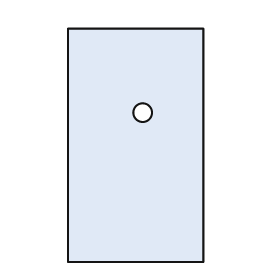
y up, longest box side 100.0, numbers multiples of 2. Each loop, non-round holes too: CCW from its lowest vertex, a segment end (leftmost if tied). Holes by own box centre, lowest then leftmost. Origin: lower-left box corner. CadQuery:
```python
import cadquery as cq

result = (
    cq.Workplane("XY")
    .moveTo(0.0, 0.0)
    .lineTo(58.0, 0.0)
    .lineTo(58.0, 100.0)
    .lineTo(0.0, 100.0)
    .close()
    .moveTo(32.0, 64.0)
    .circle(4.0)
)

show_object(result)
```